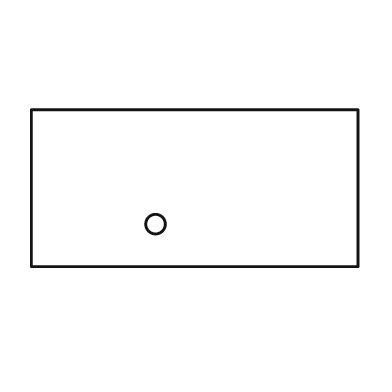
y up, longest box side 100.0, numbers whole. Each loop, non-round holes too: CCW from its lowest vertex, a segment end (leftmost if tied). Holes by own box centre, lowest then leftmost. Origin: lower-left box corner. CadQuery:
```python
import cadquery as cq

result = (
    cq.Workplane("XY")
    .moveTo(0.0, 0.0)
    .lineTo(100.0, 0.0)
    .lineTo(100.0, 48.0)
    .lineTo(0.0, 48.0)
    .close()
    .moveTo(38.0, 13.0)
    .circle(3.0)
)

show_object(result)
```